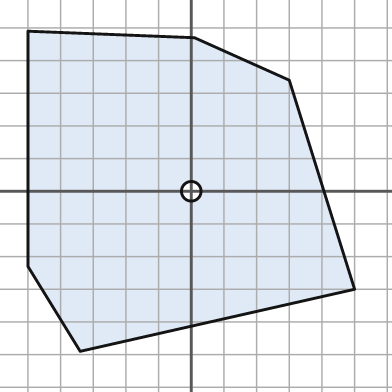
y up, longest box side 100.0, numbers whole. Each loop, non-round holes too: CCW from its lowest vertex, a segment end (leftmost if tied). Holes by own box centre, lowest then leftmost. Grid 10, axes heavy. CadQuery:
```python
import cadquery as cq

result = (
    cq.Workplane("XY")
    .moveTo(-34.0, -49.0)
    .lineTo(50.0, -30.0)
    .lineTo(30.0, 34.0)
    .lineTo(1.0, 47.0)
    .lineTo(-50.0, 49.0)
    .lineTo(-50.0, -23.0)
    .close()
    .moveTo(0.0, 0.0)
    .circle(3.0)
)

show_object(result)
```